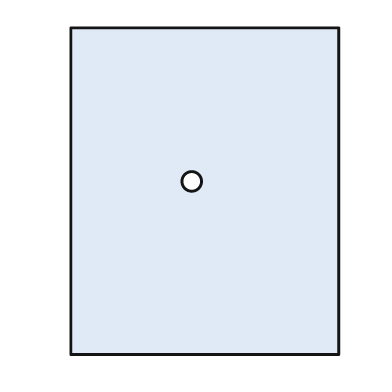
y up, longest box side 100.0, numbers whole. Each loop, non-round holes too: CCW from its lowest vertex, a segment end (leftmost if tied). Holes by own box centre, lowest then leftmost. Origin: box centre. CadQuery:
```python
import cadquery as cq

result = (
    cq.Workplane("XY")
    .moveTo(-41.0, -50.0)
    .lineTo(41.0, -50.0)
    .lineTo(41.0, 50.0)
    .lineTo(-41.0, 50.0)
    .close()
    .moveTo(-4.0, 3.0)
    .circle(3.0)
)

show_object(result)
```